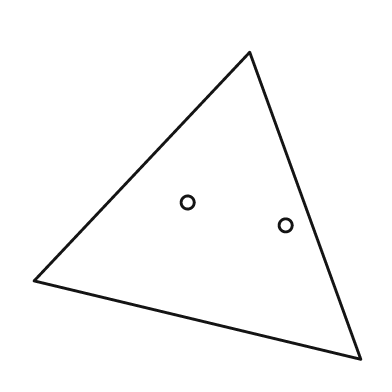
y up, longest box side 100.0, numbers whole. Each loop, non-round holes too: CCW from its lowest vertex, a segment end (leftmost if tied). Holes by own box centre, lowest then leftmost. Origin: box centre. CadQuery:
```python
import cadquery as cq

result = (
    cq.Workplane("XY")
    .moveTo(50.0, -47.0)
    .lineTo(16.0, 47.0)
    .lineTo(-50.0, -23.0)
    .close()
    .moveTo(27.0, -6.0)
    .circle(2.0)
    .moveTo(-3.0, 1.0)
    .circle(2.0)
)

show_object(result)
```